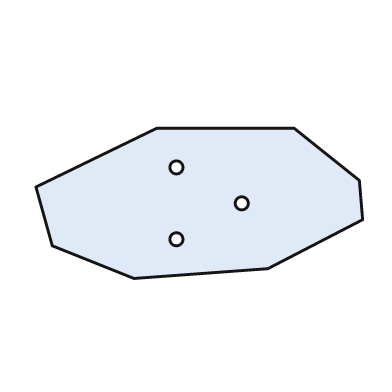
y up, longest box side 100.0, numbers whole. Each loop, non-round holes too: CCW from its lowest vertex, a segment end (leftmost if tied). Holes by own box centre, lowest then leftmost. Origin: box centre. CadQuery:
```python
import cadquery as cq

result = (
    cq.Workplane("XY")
    .moveTo(-20.0, -23.0)
    .lineTo(21.0, -20.0)
    .lineTo(50.0, -5.0)
    .lineTo(49.0, 7.0)
    .lineTo(29.0, 23.0)
    .lineTo(-13.0, 23.0)
    .lineTo(-50.0, 5.0)
    .lineTo(-45.0, -13.0)
    .close()
    .moveTo(-7.0, -11.0)
    .circle(2.0)
    .moveTo(13.0, 0.0)
    .circle(2.0)
    .moveTo(-7.0, 11.0)
    .circle(2.0)
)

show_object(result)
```